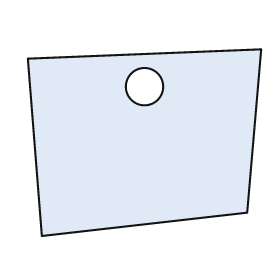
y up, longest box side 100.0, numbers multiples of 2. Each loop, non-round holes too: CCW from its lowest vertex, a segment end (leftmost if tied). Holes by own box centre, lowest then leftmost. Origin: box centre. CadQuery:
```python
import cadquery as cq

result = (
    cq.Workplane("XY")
    .moveTo(-44.0, -40.0)
    .lineTo(44.0, -30.0)
    .lineTo(50.0, 40.0)
    .lineTo(-50.0, 36.0)
    .close()
    .moveTo(0.0, 24.0)
    .circle(8.0)
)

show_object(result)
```